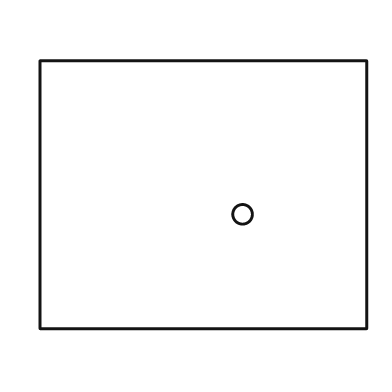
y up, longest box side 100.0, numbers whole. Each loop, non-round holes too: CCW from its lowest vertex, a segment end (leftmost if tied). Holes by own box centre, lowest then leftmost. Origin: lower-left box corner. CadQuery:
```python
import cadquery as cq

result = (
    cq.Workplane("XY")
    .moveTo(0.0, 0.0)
    .lineTo(100.0, 0.0)
    .lineTo(100.0, 82.0)
    .lineTo(0.0, 82.0)
    .close()
    .moveTo(62.0, 35.0)
    .circle(3.0)
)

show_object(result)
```